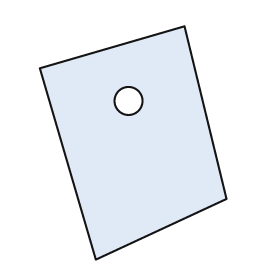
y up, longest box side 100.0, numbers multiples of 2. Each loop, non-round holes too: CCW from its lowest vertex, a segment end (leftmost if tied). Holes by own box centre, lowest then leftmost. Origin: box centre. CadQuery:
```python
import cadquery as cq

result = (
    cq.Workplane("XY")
    .moveTo(-16.0, -50.0)
    .lineTo(40.0, -24.0)
    .lineTo(22.0, 50.0)
    .lineTo(-40.0, 32.0)
    .close()
    .moveTo(-2.0, 18.0)
    .circle(6.0)
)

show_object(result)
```